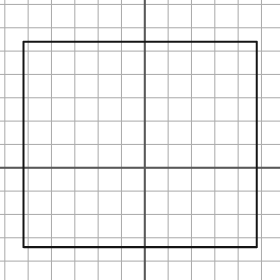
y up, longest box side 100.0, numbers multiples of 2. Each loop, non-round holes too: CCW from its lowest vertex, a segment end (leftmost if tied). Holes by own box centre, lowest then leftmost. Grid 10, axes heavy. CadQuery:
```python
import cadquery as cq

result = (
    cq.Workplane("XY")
    .moveTo(-52.0, -34.0)
    .lineTo(48.0, -34.0)
    .lineTo(48.0, 54.0)
    .lineTo(-52.0, 54.0)
    .close()
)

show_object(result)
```